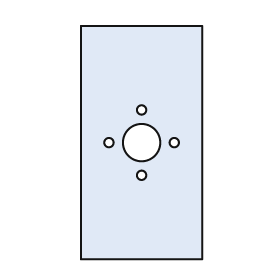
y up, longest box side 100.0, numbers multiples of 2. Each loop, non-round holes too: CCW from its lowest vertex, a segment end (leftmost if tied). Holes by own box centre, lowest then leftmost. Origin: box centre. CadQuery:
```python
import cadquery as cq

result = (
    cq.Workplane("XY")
    .moveTo(-26.0, -50.0)
    .lineTo(26.0, -50.0)
    .lineTo(26.0, 50.0)
    .lineTo(-26.0, 50.0)
    .close()
    .moveTo(0.0, -14.0)
    .circle(2.0)
    .moveTo(-14.0, 0.0)
    .circle(2.0)
    .moveTo(0.0, 0.0)
    .circle(8.0)
    .moveTo(14.0, 0.0)
    .circle(2.0)
    .moveTo(0.0, 14.0)
    .circle(2.0)
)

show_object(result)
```